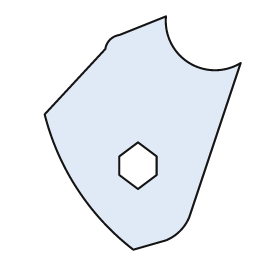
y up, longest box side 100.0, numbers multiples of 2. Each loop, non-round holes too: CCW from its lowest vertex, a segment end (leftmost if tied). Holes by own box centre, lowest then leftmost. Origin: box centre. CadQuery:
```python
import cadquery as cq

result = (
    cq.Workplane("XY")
    .moveTo(-4.0, -50.0)
    .lineTo(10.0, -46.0)
    .threePointArc((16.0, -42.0), (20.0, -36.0))
    .lineTo(42.0, 30.0)
    .threePointArc((20.0, 30.0), (10.0, 50.0))
    .lineTo(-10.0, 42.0)
    .threePointArc((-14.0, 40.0), (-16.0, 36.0))
    .lineTo(-42.0, 8.0)
    .threePointArc((-28.0, -24.0), (-4.0, -50.0))
    .close()
    .moveTo(-2.0, -24.0)
    .lineTo(6.0, -18.0)
    .lineTo(6.0, -10.0)
    .lineTo(-2.0, -4.0)
    .lineTo(-10.0, -10.0)
    .lineTo(-10.0, -18.0)
    .close()
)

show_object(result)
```